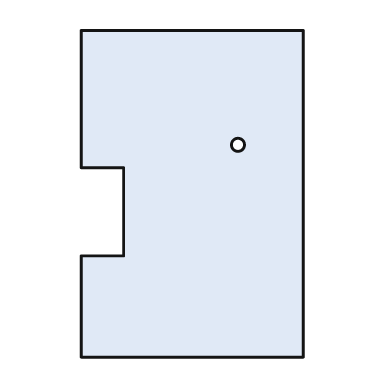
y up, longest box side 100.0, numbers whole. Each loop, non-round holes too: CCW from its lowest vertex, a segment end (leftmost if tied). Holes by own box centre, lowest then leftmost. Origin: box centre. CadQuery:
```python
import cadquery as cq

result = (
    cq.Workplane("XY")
    .moveTo(-34.0, -50.0)
    .lineTo(34.0, -50.0)
    .lineTo(34.0, 50.0)
    .lineTo(-34.0, 50.0)
    .lineTo(-34.0, 8.0)
    .lineTo(-21.0, 8.0)
    .lineTo(-21.0, -19.0)
    .lineTo(-34.0, -19.0)
    .close()
    .moveTo(14.0, 15.0)
    .circle(2.0)
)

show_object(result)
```